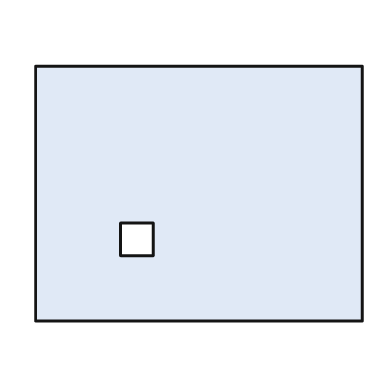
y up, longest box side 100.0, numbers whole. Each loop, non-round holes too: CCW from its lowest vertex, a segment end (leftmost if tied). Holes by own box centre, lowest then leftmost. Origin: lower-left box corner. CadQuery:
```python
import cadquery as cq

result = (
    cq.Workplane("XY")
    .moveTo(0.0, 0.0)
    .lineTo(100.0, 0.0)
    .lineTo(100.0, 78.0)
    .lineTo(0.0, 78.0)
    .close()
    .moveTo(26.0, 20.0)
    .lineTo(36.0, 20.0)
    .lineTo(36.0, 30.0)
    .lineTo(26.0, 30.0)
    .close()
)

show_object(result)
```